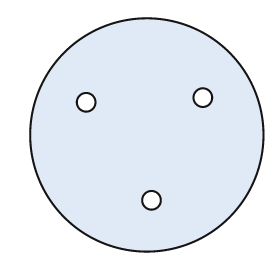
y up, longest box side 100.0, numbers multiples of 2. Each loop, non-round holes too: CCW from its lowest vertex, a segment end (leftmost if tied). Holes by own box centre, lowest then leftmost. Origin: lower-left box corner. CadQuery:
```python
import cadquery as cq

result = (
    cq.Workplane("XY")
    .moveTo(50.0, 50.0)
    .circle(50.0)
    .moveTo(52.0, 22.0)
    .circle(4.0)
    .moveTo(24.0, 64.0)
    .circle(4.0)
    .moveTo(74.0, 66.0)
    .circle(4.0)
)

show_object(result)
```